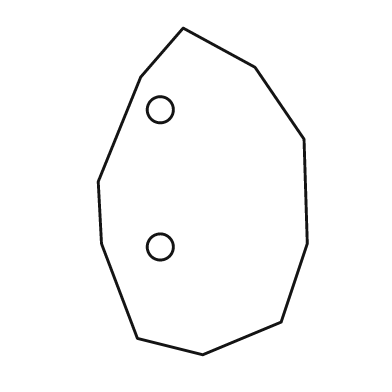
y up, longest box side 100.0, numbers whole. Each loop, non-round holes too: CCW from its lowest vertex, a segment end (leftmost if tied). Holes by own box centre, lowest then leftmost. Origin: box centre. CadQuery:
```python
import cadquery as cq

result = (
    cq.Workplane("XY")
    .moveTo(0.0, -50.0)
    .lineTo(24.0, -40.0)
    .lineTo(32.0, -16.0)
    .lineTo(31.0, 16.0)
    .lineTo(16.0, 38.0)
    .lineTo(-6.0, 50.0)
    .lineTo(-19.0, 35.0)
    .lineTo(-32.0, 3.0)
    .lineTo(-31.0, -16.0)
    .lineTo(-20.0, -45.0)
    .close()
    .moveTo(-13.0, -17.0)
    .circle(4.0)
    .moveTo(-13.0, 25.0)
    .circle(4.0)
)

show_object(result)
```